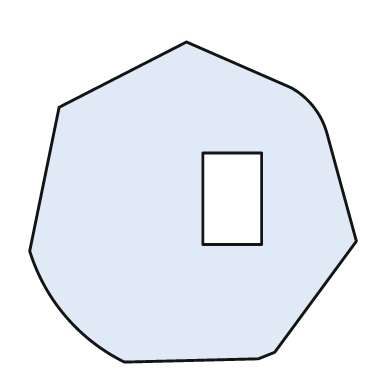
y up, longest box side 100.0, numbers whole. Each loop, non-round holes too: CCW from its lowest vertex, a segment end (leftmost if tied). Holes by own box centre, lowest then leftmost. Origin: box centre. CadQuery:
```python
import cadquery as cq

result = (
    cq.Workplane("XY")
    .moveTo(-21.0, -49.0)
    .lineTo(20.0, -48.0)
    .lineTo(25.0, -46.0)
    .lineTo(50.0, -12.0)
    .lineTo(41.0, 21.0)
    .threePointArc((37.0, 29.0), (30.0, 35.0))
    .lineTo(-2.0, 49.0)
    .lineTo(-41.0, 29.0)
    .lineTo(-50.0, -15.0)
    .threePointArc((-39.0, -35.0), (-21.0, -49.0))
    .close()
    .moveTo(3.0, -13.0)
    .lineTo(21.0, -13.0)
    .lineTo(21.0, 15.0)
    .lineTo(3.0, 15.0)
    .close()
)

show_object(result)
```